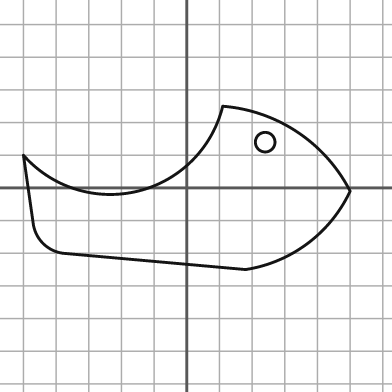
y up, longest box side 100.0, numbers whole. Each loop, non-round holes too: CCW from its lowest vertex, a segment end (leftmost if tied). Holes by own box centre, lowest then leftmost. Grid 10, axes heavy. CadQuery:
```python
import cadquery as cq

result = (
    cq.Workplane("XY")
    .moveTo(18.0, -25.0)
    .threePointArc((37.0, -17.0), (50.0, -1.0))
    .threePointArc((34.0, 17.0), (11.0, 25.0))
    .threePointArc((-15.0, -1.0), (-50.0, 10.0))
    .lineTo(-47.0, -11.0)
    .threePointArc((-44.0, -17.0), (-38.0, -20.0))
    .close()
    .moveTo(24.0, 14.0)
    .circle(3.0)
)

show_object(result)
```